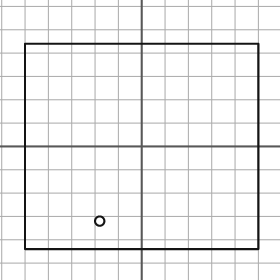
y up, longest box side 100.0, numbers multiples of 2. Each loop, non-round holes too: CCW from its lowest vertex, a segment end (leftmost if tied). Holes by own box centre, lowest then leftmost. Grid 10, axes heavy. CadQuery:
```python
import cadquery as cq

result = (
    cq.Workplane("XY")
    .moveTo(-50.0, -44.0)
    .lineTo(50.0, -44.0)
    .lineTo(50.0, 44.0)
    .lineTo(-50.0, 44.0)
    .close()
    .moveTo(-18.0, -32.0)
    .circle(2.0)
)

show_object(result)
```